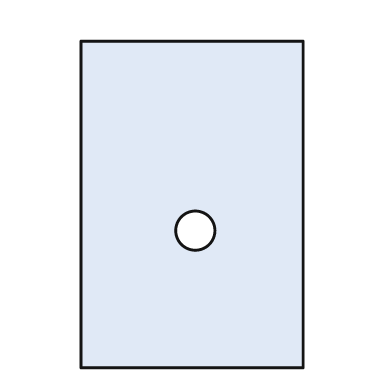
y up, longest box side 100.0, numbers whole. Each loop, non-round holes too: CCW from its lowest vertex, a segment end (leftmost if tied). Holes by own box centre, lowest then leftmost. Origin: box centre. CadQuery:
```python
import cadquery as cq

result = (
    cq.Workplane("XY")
    .moveTo(-34.0, -50.0)
    .lineTo(34.0, -50.0)
    .lineTo(34.0, 50.0)
    .lineTo(-34.0, 50.0)
    .close()
    .moveTo(1.0, -8.0)
    .circle(6.0)
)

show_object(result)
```